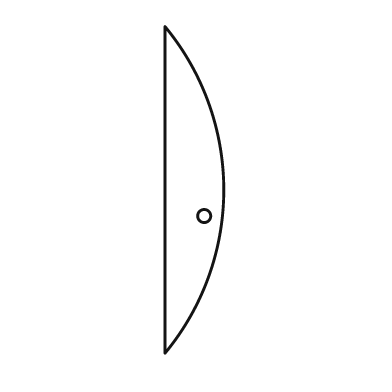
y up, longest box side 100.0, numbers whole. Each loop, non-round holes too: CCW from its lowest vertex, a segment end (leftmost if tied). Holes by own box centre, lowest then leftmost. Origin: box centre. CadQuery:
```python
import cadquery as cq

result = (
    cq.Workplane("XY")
    .moveTo(-9.0, -50.0)
    .threePointArc((9.0, 0.0), (-9.0, 50.0))
    .close()
    .moveTo(3.0, -8.0)
    .circle(2.0)
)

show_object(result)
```